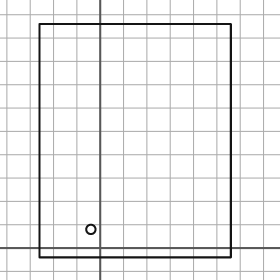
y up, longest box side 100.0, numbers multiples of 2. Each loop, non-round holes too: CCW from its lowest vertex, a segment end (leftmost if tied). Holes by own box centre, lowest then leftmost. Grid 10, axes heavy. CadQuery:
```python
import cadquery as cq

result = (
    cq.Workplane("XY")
    .moveTo(-26.0, -4.0)
    .lineTo(56.0, -4.0)
    .lineTo(56.0, 96.0)
    .lineTo(-26.0, 96.0)
    .close()
    .moveTo(-4.0, 8.0)
    .circle(2.0)
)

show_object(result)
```